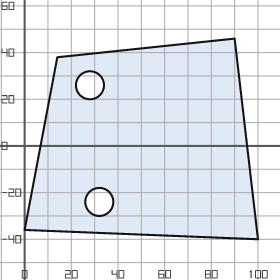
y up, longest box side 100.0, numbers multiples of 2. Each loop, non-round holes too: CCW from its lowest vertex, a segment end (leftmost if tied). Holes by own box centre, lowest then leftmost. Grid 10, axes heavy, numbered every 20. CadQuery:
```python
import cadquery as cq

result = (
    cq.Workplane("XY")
    .moveTo(100.0, -40.0)
    .lineTo(90.0, 46.0)
    .lineTo(14.0, 38.0)
    .lineTo(0.0, -36.0)
    .close()
    .moveTo(32.0, -24.0)
    .circle(6.0)
    .moveTo(28.0, 26.0)
    .circle(6.0)
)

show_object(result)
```